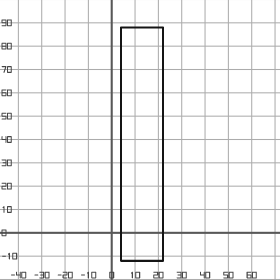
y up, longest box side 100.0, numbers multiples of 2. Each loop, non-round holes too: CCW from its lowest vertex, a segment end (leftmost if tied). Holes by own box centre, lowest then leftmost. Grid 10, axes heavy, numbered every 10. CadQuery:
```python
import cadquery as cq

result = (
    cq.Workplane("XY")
    .moveTo(4.0, -12.0)
    .lineTo(22.0, -12.0)
    .lineTo(22.0, 88.0)
    .lineTo(4.0, 88.0)
    .close()
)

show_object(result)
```